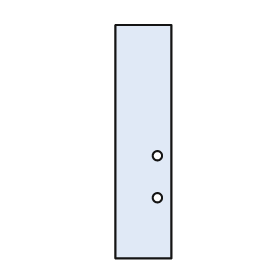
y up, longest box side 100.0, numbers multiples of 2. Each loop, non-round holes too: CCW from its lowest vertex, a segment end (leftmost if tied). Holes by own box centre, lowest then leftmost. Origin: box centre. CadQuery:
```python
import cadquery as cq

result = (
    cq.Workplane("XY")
    .moveTo(-12.0, -50.0)
    .lineTo(12.0, -50.0)
    .lineTo(12.0, 50.0)
    .lineTo(-12.0, 50.0)
    .close()
    .moveTo(6.0, -24.0)
    .circle(2.0)
    .moveTo(6.0, -6.0)
    .circle(2.0)
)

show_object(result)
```